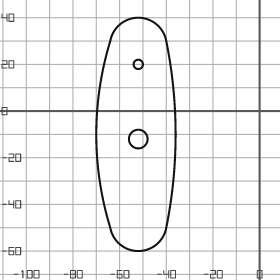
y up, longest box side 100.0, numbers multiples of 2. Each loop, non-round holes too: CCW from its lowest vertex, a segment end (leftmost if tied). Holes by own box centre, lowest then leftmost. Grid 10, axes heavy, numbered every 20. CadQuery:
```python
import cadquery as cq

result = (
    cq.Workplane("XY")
    .moveTo(-64.0, -50.0)
    .threePointArc((-52.0, -60.0), (-40.0, -50.0))
    .threePointArc((-36.0, -10.0), (-40.0, 30.0))
    .threePointArc((-52.0, 40.0), (-64.0, 30.0))
    .threePointArc((-70.0, -10.0), (-64.0, -50.0))
    .close()
    .moveTo(-52.0, -12.0)
    .circle(4.0)
    .moveTo(-52.0, 20.0)
    .circle(2.0)
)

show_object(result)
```